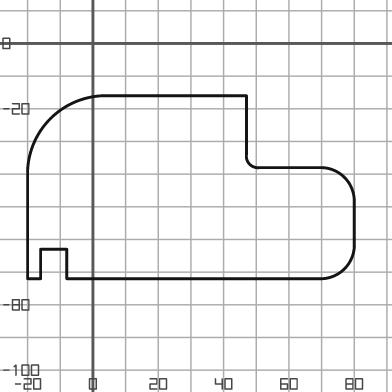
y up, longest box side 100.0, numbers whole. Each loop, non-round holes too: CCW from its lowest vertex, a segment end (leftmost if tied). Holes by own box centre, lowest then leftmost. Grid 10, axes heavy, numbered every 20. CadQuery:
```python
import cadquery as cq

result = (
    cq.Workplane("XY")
    .moveTo(-20.0, -72.0)
    .lineTo(-16.0, -72.0)
    .lineTo(-16.0, -63.0)
    .lineTo(-8.0, -63.0)
    .lineTo(-8.0, -72.0)
    .lineTo(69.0, -72.0)
    .threePointArc((77.0, -69.0), (80.0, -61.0))
    .lineTo(80.0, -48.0)
    .threePointArc((77.0, -41.0), (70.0, -38.0))
    .lineTo(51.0, -38.0)
    .threePointArc((48.0, -37.0), (47.0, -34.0))
    .lineTo(47.0, -16.0)
    .lineTo(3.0, -16.0)
    .threePointArc((-13.0, -23.0), (-20.0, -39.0))
    .close()
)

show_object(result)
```